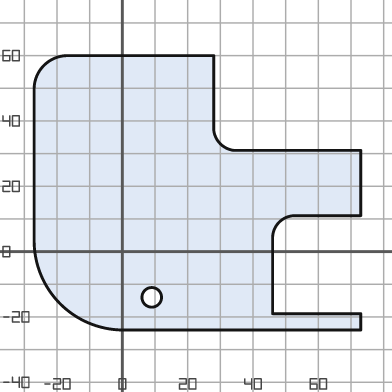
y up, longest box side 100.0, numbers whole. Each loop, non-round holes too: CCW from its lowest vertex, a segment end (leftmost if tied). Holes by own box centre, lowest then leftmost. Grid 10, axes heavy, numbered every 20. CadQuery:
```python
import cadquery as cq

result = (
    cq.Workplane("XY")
    .moveTo(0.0, -24.0)
    .lineTo(73.0, -24.0)
    .lineTo(73.0, -19.0)
    .lineTo(46.0, -19.0)
    .lineTo(46.0, 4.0)
    .threePointArc((48.0, 9.0), (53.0, 11.0))
    .lineTo(73.0, 11.0)
    .lineTo(73.0, 31.0)
    .lineTo(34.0, 31.0)
    .threePointArc((30.0, 33.0), (28.0, 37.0))
    .lineTo(28.0, 60.0)
    .lineTo(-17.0, 60.0)
    .threePointArc((-24.0, 57.0), (-27.0, 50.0))
    .lineTo(-27.0, 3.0)
    .threePointArc((-19.0, -16.0), (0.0, -24.0))
    .close()
    .moveTo(9.0, -14.0)
    .circle(3.0)
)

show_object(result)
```